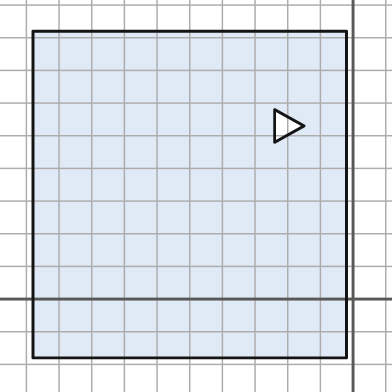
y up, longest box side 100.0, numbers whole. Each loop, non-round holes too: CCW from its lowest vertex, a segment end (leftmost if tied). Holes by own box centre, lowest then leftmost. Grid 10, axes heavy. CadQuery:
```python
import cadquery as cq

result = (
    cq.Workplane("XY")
    .moveTo(-98.0, -18.0)
    .lineTo(-2.0, -18.0)
    .lineTo(-2.0, 82.0)
    .lineTo(-98.0, 82.0)
    .close()
    .moveTo(-24.0, 48.0)
    .lineTo(-15.0, 53.0)
    .lineTo(-24.0, 58.0)
    .close()
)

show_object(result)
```